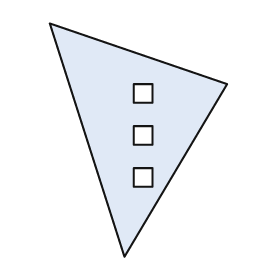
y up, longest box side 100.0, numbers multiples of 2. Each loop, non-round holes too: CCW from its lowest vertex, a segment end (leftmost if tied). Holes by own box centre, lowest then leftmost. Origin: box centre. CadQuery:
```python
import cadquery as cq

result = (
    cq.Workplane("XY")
    .moveTo(-6.0, -50.0)
    .lineTo(38.0, 24.0)
    .lineTo(-38.0, 50.0)
    .close()
    .moveTo(-2.0, -20.0)
    .lineTo(6.0, -20.0)
    .lineTo(6.0, -12.0)
    .lineTo(-2.0, -12.0)
    .close()
    .moveTo(-2.0, -2.0)
    .lineTo(6.0, -2.0)
    .lineTo(6.0, 6.0)
    .lineTo(-2.0, 6.0)
    .close()
    .moveTo(-2.0, 16.0)
    .lineTo(6.0, 16.0)
    .lineTo(6.0, 24.0)
    .lineTo(-2.0, 24.0)
    .close()
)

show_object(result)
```